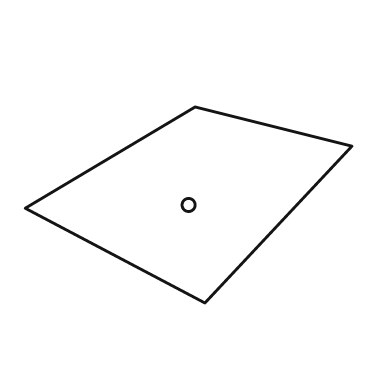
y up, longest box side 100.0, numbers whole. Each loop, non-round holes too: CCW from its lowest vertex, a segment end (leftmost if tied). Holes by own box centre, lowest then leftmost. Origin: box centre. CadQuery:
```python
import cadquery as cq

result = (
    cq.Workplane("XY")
    .moveTo(5.0, -30.0)
    .lineTo(50.0, 18.0)
    .lineTo(2.0, 30.0)
    .lineTo(-50.0, -1.0)
    .close()
    .moveTo(0.0, 0.0)
    .circle(2.0)
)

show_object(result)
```